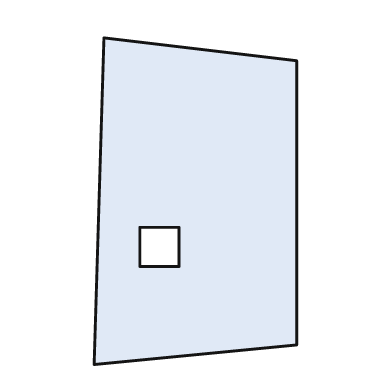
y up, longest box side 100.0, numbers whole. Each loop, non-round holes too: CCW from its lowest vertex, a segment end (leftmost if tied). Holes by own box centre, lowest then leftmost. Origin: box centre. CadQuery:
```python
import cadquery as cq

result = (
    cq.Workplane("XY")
    .moveTo(-31.0, -50.0)
    .lineTo(31.0, -44.0)
    .lineTo(31.0, 43.0)
    .lineTo(-28.0, 50.0)
    .close()
    .moveTo(-17.0, -20.0)
    .lineTo(-5.0, -20.0)
    .lineTo(-5.0, -8.0)
    .lineTo(-17.0, -8.0)
    .close()
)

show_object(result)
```